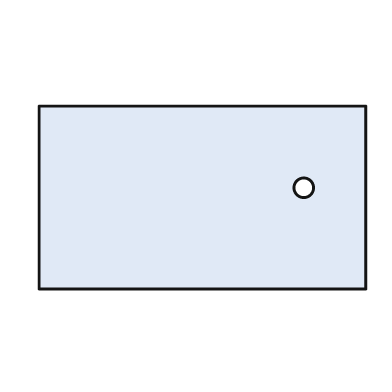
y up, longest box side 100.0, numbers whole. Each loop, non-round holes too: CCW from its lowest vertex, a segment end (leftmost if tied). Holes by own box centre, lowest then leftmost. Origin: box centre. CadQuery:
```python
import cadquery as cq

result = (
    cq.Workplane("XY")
    .moveTo(-50.0, -28.0)
    .lineTo(50.0, -28.0)
    .lineTo(50.0, 28.0)
    .lineTo(-50.0, 28.0)
    .close()
    .moveTo(31.0, 3.0)
    .circle(3.0)
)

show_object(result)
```